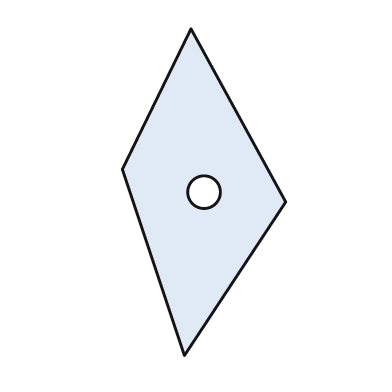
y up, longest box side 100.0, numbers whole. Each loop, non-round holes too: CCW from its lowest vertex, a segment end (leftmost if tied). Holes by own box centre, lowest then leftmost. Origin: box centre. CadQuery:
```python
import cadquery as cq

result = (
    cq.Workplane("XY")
    .moveTo(-6.0, -50.0)
    .lineTo(25.0, -3.0)
    .lineTo(-4.0, 50.0)
    .lineTo(-25.0, 7.0)
    .close()
    .moveTo(0.0, 0.0)
    .circle(5.0)
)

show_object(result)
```